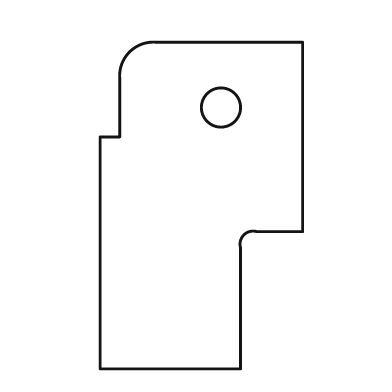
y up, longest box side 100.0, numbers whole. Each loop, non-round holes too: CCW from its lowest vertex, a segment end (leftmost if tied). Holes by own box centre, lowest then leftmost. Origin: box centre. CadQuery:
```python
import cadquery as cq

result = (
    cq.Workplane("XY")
    .moveTo(-31.0, -50.0)
    .lineTo(12.0, -50.0)
    .lineTo(12.0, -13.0)
    .threePointArc((13.0, -9.0), (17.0, -8.0))
    .lineTo(31.0, -8.0)
    .lineTo(31.0, 50.0)
    .lineTo(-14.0, 50.0)
    .threePointArc((-22.0, 47.0), (-25.0, 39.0))
    .lineTo(-25.0, 21.0)
    .lineTo(-31.0, 21.0)
    .close()
    .moveTo(6.0, 30.0)
    .circle(6.0)
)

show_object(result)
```